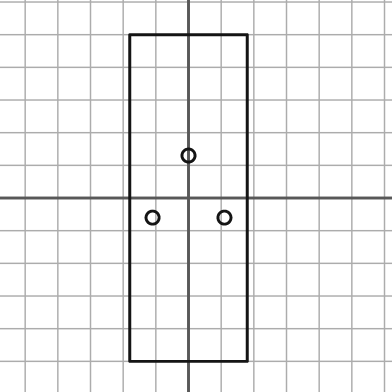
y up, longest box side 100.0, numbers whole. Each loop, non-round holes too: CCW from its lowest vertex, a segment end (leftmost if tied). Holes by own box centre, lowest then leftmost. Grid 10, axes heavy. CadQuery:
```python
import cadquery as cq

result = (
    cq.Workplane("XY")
    .moveTo(-18.0, -50.0)
    .lineTo(18.0, -50.0)
    .lineTo(18.0, 50.0)
    .lineTo(-18.0, 50.0)
    .close()
    .moveTo(-11.0, -6.0)
    .circle(2.0)
    .moveTo(11.0, -6.0)
    .circle(2.0)
    .moveTo(0.0, 13.0)
    .circle(2.0)
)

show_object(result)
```